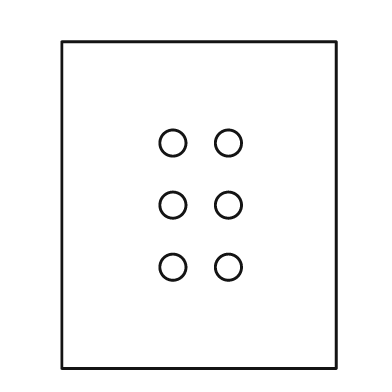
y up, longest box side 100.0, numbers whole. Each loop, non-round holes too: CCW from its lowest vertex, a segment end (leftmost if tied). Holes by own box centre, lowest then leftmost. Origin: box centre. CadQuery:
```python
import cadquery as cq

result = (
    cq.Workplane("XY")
    .moveTo(-42.0, -50.0)
    .lineTo(42.0, -50.0)
    .lineTo(42.0, 50.0)
    .lineTo(-42.0, 50.0)
    .close()
    .moveTo(-8.0, -19.0)
    .circle(4.0)
    .moveTo(9.0, -19.0)
    .circle(4.0)
    .moveTo(-8.0, 0.0)
    .circle(4.0)
    .moveTo(9.0, 0.0)
    .circle(4.0)
    .moveTo(-8.0, 19.0)
    .circle(4.0)
    .moveTo(9.0, 19.0)
    .circle(4.0)
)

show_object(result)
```